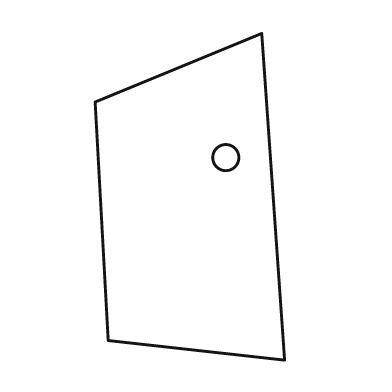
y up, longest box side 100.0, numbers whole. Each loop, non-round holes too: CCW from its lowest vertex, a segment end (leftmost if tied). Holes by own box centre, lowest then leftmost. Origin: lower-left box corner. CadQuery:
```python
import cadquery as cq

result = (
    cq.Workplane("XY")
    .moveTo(58.0, 0.0)
    .lineTo(51.0, 100.0)
    .lineTo(0.0, 79.0)
    .lineTo(4.0, 6.0)
    .close()
    .moveTo(40.0, 62.0)
    .circle(4.0)
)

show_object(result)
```